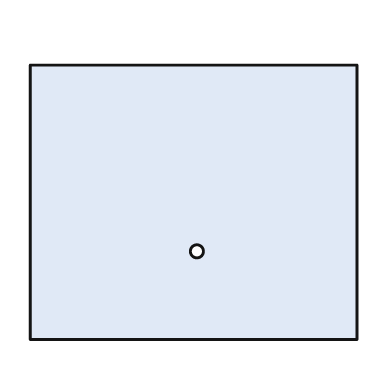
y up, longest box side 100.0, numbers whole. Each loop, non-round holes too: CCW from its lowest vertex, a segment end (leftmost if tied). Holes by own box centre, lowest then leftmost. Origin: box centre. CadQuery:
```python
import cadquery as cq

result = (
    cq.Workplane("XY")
    .moveTo(-50.0, -42.0)
    .lineTo(50.0, -42.0)
    .lineTo(50.0, 42.0)
    .lineTo(-50.0, 42.0)
    .close()
    .moveTo(1.0, -15.0)
    .circle(2.0)
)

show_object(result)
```